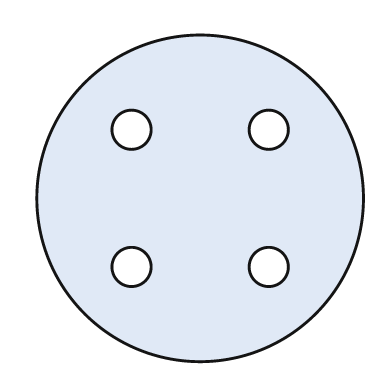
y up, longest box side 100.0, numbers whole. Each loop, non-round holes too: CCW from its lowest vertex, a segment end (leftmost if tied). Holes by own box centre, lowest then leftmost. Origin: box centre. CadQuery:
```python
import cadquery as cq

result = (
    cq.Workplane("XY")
    .moveTo(0.0, 0.0)
    .circle(50.0)
    .moveTo(-21.0, -21.0)
    .circle(6.0)
    .moveTo(21.0, -21.0)
    .circle(6.0)
    .moveTo(-21.0, 21.0)
    .circle(6.0)
    .moveTo(21.0, 21.0)
    .circle(6.0)
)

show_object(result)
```